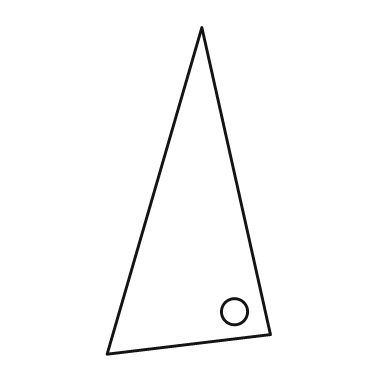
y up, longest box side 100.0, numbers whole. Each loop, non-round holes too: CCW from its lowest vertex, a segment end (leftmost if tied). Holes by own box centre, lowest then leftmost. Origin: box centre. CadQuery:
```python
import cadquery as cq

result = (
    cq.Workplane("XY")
    .moveTo(-25.0, -50.0)
    .lineTo(25.0, -44.0)
    .lineTo(4.0, 50.0)
    .close()
    .moveTo(14.0, -37.0)
    .circle(4.0)
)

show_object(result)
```